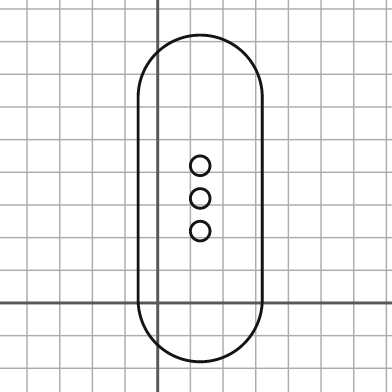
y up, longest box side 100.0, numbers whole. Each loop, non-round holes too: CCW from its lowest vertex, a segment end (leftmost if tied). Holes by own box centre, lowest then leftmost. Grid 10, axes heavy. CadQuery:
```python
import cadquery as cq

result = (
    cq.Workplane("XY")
    .moveTo(-6.0, 1.0)
    .threePointArc((13.0, -18.0), (32.0, 1.0))
    .lineTo(32.0, 63.0)
    .threePointArc((13.0, 82.0), (-6.0, 63.0))
    .close()
    .moveTo(13.0, 22.0)
    .circle(3.0)
    .moveTo(13.0, 32.0)
    .circle(3.0)
    .moveTo(13.0, 42.0)
    .circle(3.0)
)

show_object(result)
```